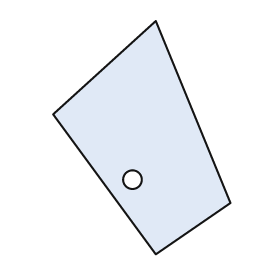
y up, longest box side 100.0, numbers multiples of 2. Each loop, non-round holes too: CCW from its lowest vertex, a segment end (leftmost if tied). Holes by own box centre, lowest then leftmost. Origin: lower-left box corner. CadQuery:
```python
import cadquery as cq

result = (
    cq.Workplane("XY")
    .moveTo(44.0, 0.0)
    .lineTo(76.0, 22.0)
    .lineTo(44.0, 100.0)
    .lineTo(0.0, 60.0)
    .close()
    .moveTo(34.0, 32.0)
    .circle(4.0)
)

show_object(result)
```